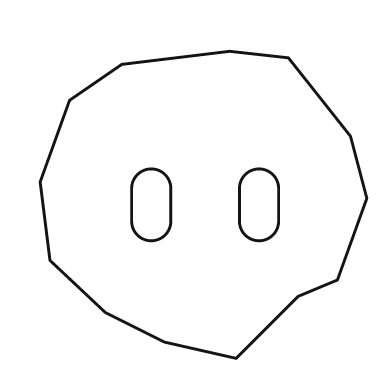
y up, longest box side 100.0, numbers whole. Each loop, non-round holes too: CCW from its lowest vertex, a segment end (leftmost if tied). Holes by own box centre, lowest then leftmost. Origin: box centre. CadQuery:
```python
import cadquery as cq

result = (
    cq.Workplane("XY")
    .moveTo(10.0, -47.0)
    .lineTo(29.0, -28.0)
    .lineTo(41.0, -23.0)
    .lineTo(50.0, 2.0)
    .lineTo(45.0, 21.0)
    .lineTo(26.0, 45.0)
    .lineTo(8.0, 47.0)
    .lineTo(-25.0, 43.0)
    .lineTo(-41.0, 32.0)
    .lineTo(-50.0, 7.0)
    .lineTo(-47.0, -17.0)
    .lineTo(-30.0, -33.0)
    .lineTo(-12.0, -42.0)
    .close()
    .moveTo(-22.0, -5.0)
    .threePointArc((-16.0, -11.0), (-10.0, -5.0))
    .lineTo(-10.0, 5.0)
    .threePointArc((-16.0, 11.0), (-22.0, 5.0))
    .close()
    .moveTo(11.0, -5.0)
    .threePointArc((17.0, -11.0), (23.0, -5.0))
    .lineTo(23.0, 5.0)
    .threePointArc((17.0, 11.0), (11.0, 5.0))
    .close()
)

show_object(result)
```